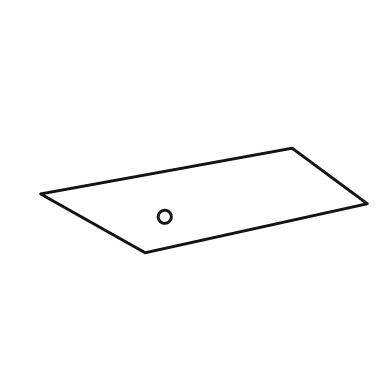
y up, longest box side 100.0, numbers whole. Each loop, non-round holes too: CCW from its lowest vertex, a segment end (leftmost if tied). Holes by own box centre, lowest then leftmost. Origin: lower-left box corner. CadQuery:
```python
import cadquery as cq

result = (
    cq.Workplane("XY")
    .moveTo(32.0, 0.0)
    .lineTo(100.0, 15.0)
    .lineTo(77.0, 32.0)
    .lineTo(0.0, 18.0)
    .close()
    .moveTo(38.0, 11.0)
    .circle(2.0)
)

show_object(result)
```